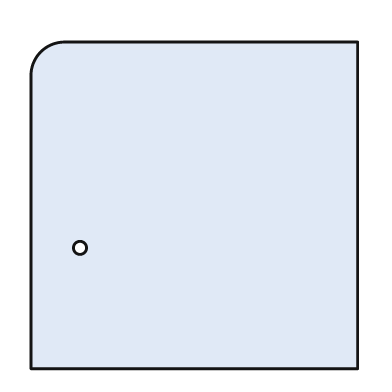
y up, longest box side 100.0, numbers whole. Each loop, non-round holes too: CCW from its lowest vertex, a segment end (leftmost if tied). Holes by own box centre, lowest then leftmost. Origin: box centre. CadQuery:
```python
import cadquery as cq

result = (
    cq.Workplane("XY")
    .moveTo(-50.0, -50.0)
    .lineTo(50.0, -50.0)
    .lineTo(50.0, 50.0)
    .lineTo(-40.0, 50.0)
    .threePointArc((-47.0, 47.0), (-50.0, 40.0))
    .close()
    .moveTo(-35.0, -13.0)
    .circle(2.0)
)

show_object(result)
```